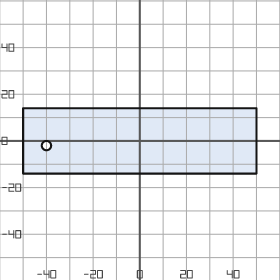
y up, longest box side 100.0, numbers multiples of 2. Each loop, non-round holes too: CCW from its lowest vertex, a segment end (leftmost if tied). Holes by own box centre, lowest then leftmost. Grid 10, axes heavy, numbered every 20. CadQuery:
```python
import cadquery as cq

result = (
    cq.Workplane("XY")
    .moveTo(-50.0, -14.0)
    .lineTo(50.0, -14.0)
    .lineTo(50.0, 14.0)
    .lineTo(-50.0, 14.0)
    .close()
    .moveTo(-40.0, -2.0)
    .circle(2.0)
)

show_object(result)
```